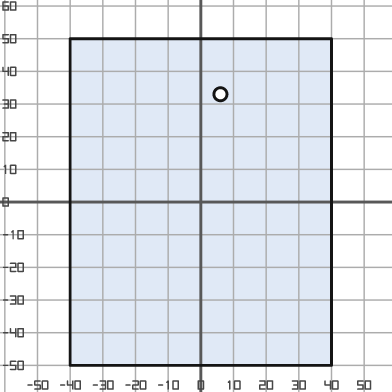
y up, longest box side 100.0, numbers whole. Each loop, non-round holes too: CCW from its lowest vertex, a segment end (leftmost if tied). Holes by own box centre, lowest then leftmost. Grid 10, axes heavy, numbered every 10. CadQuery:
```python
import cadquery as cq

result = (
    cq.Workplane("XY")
    .moveTo(-40.0, -50.0)
    .lineTo(40.0, -50.0)
    .lineTo(40.0, 50.0)
    .lineTo(-40.0, 50.0)
    .close()
    .moveTo(6.0, 33.0)
    .circle(2.0)
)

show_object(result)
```